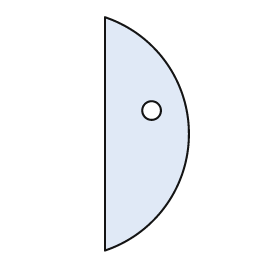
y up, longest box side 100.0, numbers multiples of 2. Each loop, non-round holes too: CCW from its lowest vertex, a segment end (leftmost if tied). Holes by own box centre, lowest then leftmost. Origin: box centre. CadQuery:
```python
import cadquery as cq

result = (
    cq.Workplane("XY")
    .moveTo(-18.0, -50.0)
    .threePointArc((18.0, 0.0), (-18.0, 50.0))
    .close()
    .moveTo(2.0, 10.0)
    .circle(4.0)
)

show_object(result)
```